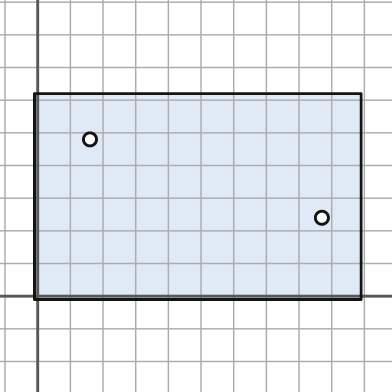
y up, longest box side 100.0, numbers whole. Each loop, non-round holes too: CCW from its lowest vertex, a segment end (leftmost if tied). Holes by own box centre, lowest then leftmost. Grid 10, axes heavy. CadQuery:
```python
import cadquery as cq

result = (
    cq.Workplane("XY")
    .moveTo(-1.0, -1.0)
    .lineTo(99.0, -1.0)
    .lineTo(99.0, 62.0)
    .lineTo(-1.0, 62.0)
    .close()
    .moveTo(87.0, 24.0)
    .circle(2.0)
    .moveTo(16.0, 48.0)
    .circle(2.0)
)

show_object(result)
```